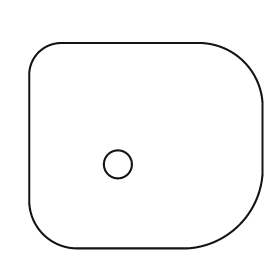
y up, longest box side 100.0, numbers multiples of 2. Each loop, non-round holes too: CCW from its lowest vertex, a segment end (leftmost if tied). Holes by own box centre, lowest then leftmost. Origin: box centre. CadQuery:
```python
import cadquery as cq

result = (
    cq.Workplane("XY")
    .moveTo(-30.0, -44.0)
    .lineTo(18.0, -44.0)
    .threePointArc((40.0, -34.0), (50.0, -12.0))
    .lineTo(50.0, 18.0)
    .threePointArc((42.0, 36.0), (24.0, 44.0))
    .lineTo(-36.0, 44.0)
    .threePointArc((-46.0, 40.0), (-50.0, 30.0))
    .lineTo(-50.0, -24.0)
    .threePointArc((-44.0, -38.0), (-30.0, -44.0))
    .close()
    .moveTo(-12.0, -8.0)
    .circle(6.0)
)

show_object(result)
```